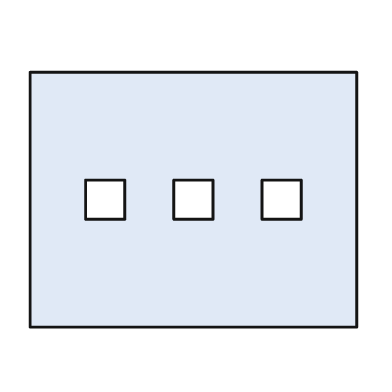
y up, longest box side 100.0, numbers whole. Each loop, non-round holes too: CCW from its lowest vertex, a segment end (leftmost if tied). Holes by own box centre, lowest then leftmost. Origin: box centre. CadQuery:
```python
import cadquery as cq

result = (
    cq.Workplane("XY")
    .moveTo(-50.0, -39.0)
    .lineTo(50.0, -39.0)
    .lineTo(50.0, 39.0)
    .lineTo(-50.0, 39.0)
    .close()
    .moveTo(-33.0, -6.0)
    .lineTo(-21.0, -6.0)
    .lineTo(-21.0, 6.0)
    .lineTo(-33.0, 6.0)
    .close()
    .moveTo(-6.0, -6.0)
    .lineTo(6.0, -6.0)
    .lineTo(6.0, 6.0)
    .lineTo(-6.0, 6.0)
    .close()
    .moveTo(21.0, -6.0)
    .lineTo(33.0, -6.0)
    .lineTo(33.0, 6.0)
    .lineTo(21.0, 6.0)
    .close()
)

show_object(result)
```